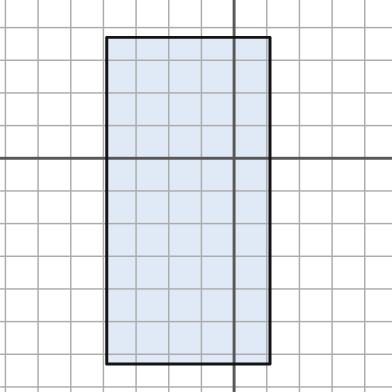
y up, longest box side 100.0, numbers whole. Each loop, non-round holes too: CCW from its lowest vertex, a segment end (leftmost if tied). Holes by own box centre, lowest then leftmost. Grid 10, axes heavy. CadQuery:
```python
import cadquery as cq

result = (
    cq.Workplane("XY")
    .moveTo(-39.0, -63.0)
    .lineTo(11.0, -63.0)
    .lineTo(11.0, 37.0)
    .lineTo(-39.0, 37.0)
    .close()
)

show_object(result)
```